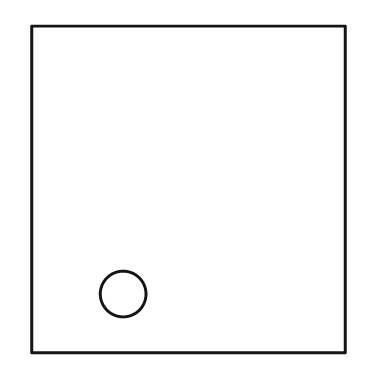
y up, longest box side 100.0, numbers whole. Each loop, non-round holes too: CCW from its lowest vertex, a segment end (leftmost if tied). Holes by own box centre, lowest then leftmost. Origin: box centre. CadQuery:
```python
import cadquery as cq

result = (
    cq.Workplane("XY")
    .moveTo(-48.0, -50.0)
    .lineTo(48.0, -50.0)
    .lineTo(48.0, 50.0)
    .lineTo(-48.0, 50.0)
    .close()
    .moveTo(-20.0, -32.0)
    .circle(7.0)
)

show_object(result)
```